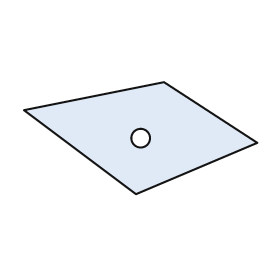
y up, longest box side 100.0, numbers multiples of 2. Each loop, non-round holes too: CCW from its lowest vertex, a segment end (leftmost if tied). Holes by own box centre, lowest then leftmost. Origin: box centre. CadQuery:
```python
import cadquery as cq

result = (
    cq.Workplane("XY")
    .moveTo(-2.0, -24.0)
    .lineTo(50.0, -2.0)
    .lineTo(10.0, 24.0)
    .lineTo(-50.0, 12.0)
    .close()
    .moveTo(0.0, 0.0)
    .circle(4.0)
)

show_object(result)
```